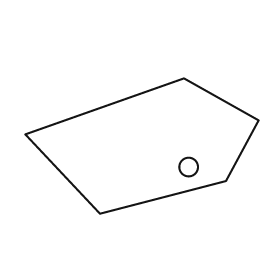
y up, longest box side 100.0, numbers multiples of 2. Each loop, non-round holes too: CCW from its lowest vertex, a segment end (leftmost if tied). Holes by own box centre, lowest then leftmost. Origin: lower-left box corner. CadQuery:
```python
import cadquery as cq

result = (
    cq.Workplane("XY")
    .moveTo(32.0, 0.0)
    .lineTo(86.0, 14.0)
    .lineTo(100.0, 40.0)
    .lineTo(68.0, 58.0)
    .lineTo(0.0, 34.0)
    .close()
    .moveTo(70.0, 20.0)
    .circle(4.0)
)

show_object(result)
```